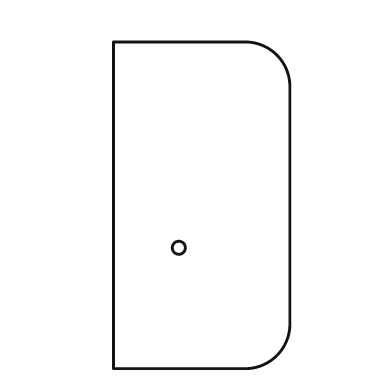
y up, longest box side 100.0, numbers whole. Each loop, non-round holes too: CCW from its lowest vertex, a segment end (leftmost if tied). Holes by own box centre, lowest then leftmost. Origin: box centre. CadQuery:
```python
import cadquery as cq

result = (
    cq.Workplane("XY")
    .moveTo(-27.0, -50.0)
    .lineTo(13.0, -50.0)
    .threePointArc((23.0, -46.0), (27.0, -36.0))
    .lineTo(27.0, 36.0)
    .threePointArc((23.0, 46.0), (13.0, 50.0))
    .lineTo(-27.0, 50.0)
    .close()
    .moveTo(-7.0, -13.0)
    .circle(2.0)
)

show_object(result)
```